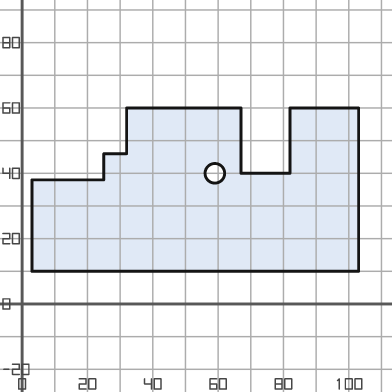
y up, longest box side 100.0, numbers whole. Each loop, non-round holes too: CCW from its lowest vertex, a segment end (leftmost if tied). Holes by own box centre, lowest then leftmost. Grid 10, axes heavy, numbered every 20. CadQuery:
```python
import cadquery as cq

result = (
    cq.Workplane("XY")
    .moveTo(3.0, 10.0)
    .lineTo(103.0, 10.0)
    .lineTo(103.0, 60.0)
    .lineTo(82.0, 60.0)
    .lineTo(82.0, 40.0)
    .lineTo(67.0, 40.0)
    .lineTo(67.0, 60.0)
    .lineTo(32.0, 60.0)
    .lineTo(32.0, 46.0)
    .lineTo(25.0, 46.0)
    .lineTo(25.0, 38.0)
    .lineTo(3.0, 38.0)
    .close()
    .moveTo(59.0, 40.0)
    .circle(3.0)
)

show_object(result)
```